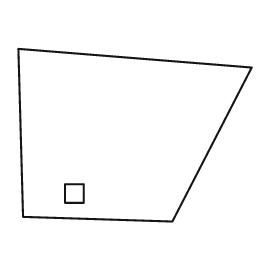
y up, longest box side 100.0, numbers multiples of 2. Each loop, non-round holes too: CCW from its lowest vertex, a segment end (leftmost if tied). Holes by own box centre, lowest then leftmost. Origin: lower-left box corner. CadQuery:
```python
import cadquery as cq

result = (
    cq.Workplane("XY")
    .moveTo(66.0, 0.0)
    .lineTo(100.0, 66.0)
    .lineTo(0.0, 74.0)
    .lineTo(2.0, 2.0)
    .close()
    .moveTo(20.0, 8.0)
    .lineTo(28.0, 8.0)
    .lineTo(28.0, 16.0)
    .lineTo(20.0, 16.0)
    .close()
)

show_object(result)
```